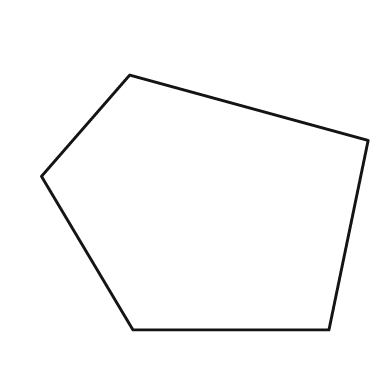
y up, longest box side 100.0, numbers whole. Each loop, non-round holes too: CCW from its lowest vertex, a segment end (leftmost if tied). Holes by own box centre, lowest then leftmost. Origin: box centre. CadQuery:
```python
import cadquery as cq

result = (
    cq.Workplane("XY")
    .moveTo(-22.0, -39.0)
    .lineTo(38.0, -39.0)
    .lineTo(50.0, 19.0)
    .lineTo(-23.0, 39.0)
    .lineTo(-50.0, 8.0)
    .close()
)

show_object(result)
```